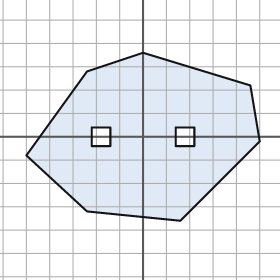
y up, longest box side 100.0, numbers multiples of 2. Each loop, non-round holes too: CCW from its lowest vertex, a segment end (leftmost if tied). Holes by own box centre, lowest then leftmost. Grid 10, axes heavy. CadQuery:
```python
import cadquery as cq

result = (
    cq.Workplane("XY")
    .moveTo(16.0, -36.0)
    .lineTo(50.0, -2.0)
    .lineTo(46.0, 22.0)
    .lineTo(0.0, 36.0)
    .lineTo(-24.0, 28.0)
    .lineTo(-50.0, -8.0)
    .lineTo(-24.0, -32.0)
    .close()
    .moveTo(-22.0, -4.0)
    .lineTo(-14.0, -4.0)
    .lineTo(-14.0, 4.0)
    .lineTo(-22.0, 4.0)
    .close()
    .moveTo(14.0, -4.0)
    .lineTo(22.0, -4.0)
    .lineTo(22.0, 4.0)
    .lineTo(14.0, 4.0)
    .close()
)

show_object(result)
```